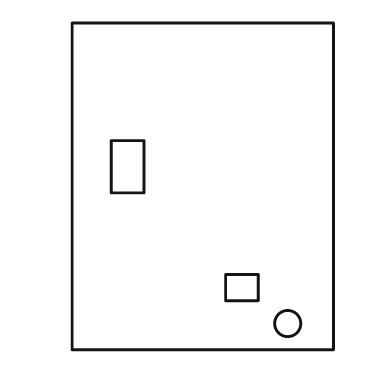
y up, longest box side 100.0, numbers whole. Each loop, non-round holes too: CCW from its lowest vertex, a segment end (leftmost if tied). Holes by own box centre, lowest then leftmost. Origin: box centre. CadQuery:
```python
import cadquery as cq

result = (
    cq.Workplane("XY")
    .moveTo(-40.0, -50.0)
    .lineTo(40.0, -50.0)
    .lineTo(40.0, 50.0)
    .lineTo(-40.0, 50.0)
    .close()
    .moveTo(26.0, -42.0)
    .circle(4.0)
    .moveTo(7.0, -35.0)
    .lineTo(17.0, -35.0)
    .lineTo(17.0, -27.0)
    .lineTo(7.0, -27.0)
    .close()
    .moveTo(-28.0, -2.0)
    .lineTo(-18.0, -2.0)
    .lineTo(-18.0, 14.0)
    .lineTo(-28.0, 14.0)
    .close()
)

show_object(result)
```